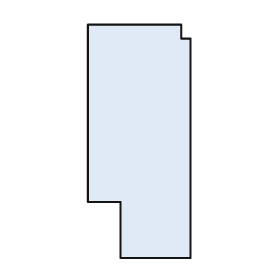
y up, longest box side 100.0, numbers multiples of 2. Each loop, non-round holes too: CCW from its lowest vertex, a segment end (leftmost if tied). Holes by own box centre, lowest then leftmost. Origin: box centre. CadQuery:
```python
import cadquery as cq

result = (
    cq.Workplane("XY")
    .moveTo(-8.0, -50.0)
    .lineTo(22.0, -50.0)
    .lineTo(22.0, 44.0)
    .lineTo(18.0, 44.0)
    .lineTo(18.0, 50.0)
    .lineTo(-22.0, 50.0)
    .lineTo(-22.0, -26.0)
    .lineTo(-8.0, -26.0)
    .close()
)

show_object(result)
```